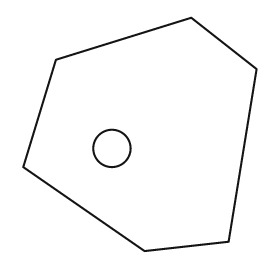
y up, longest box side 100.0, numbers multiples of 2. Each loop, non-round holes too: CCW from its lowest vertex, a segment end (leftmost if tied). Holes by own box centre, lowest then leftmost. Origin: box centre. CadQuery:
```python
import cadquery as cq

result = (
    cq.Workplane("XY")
    .moveTo(2.0, -50.0)
    .lineTo(38.0, -46.0)
    .lineTo(50.0, 28.0)
    .lineTo(22.0, 50.0)
    .lineTo(-36.0, 32.0)
    .lineTo(-50.0, -14.0)
    .close()
    .moveTo(-12.0, -6.0)
    .circle(8.0)
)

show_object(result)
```